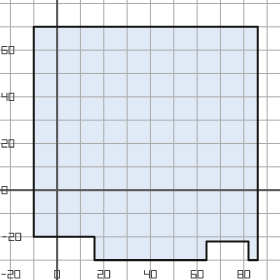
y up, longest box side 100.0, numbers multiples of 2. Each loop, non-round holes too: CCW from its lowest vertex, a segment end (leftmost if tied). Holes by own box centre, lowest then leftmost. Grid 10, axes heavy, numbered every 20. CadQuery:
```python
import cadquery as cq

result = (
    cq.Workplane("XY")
    .moveTo(16.0, -30.0)
    .lineTo(64.0, -30.0)
    .lineTo(64.0, -22.0)
    .lineTo(82.0, -22.0)
    .lineTo(82.0, -30.0)
    .lineTo(86.0, -30.0)
    .lineTo(86.0, 70.0)
    .lineTo(-10.0, 70.0)
    .lineTo(-10.0, -20.0)
    .lineTo(16.0, -20.0)
    .close()
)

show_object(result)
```